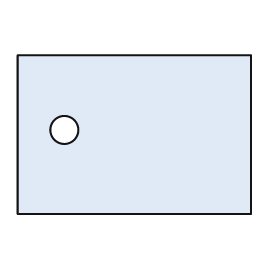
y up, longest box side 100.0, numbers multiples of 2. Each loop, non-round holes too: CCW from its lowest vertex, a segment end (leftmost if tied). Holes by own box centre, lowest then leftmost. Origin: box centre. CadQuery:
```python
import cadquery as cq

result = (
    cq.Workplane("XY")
    .moveTo(-50.0, -34.0)
    .lineTo(50.0, -34.0)
    .lineTo(50.0, 34.0)
    .lineTo(-50.0, 34.0)
    .close()
    .moveTo(-30.0, 2.0)
    .circle(6.0)
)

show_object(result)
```